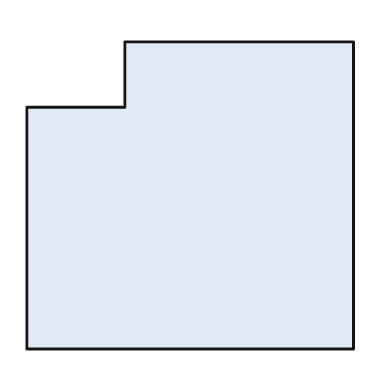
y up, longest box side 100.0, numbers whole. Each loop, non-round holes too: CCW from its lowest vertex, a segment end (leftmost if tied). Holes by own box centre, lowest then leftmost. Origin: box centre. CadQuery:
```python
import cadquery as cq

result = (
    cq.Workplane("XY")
    .moveTo(-50.0, -47.0)
    .lineTo(50.0, -47.0)
    .lineTo(50.0, 47.0)
    .lineTo(-20.0, 47.0)
    .lineTo(-20.0, 27.0)
    .lineTo(-50.0, 27.0)
    .close()
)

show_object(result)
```